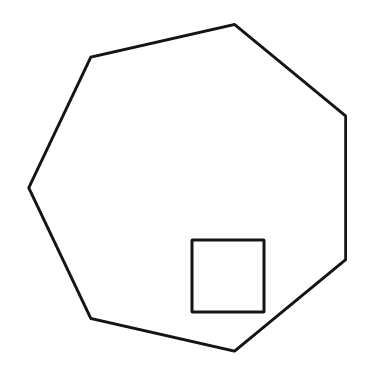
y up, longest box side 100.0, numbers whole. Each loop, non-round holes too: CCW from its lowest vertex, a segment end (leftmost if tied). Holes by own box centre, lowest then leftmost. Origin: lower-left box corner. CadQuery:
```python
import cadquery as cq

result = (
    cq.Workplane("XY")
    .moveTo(63.0, 0.0)
    .lineTo(97.0, 28.0)
    .lineTo(97.0, 72.0)
    .lineTo(63.0, 100.0)
    .lineTo(19.0, 90.0)
    .lineTo(0.0, 50.0)
    .lineTo(19.0, 10.0)
    .close()
    .moveTo(50.0, 12.0)
    .lineTo(72.0, 12.0)
    .lineTo(72.0, 34.0)
    .lineTo(50.0, 34.0)
    .close()
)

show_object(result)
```